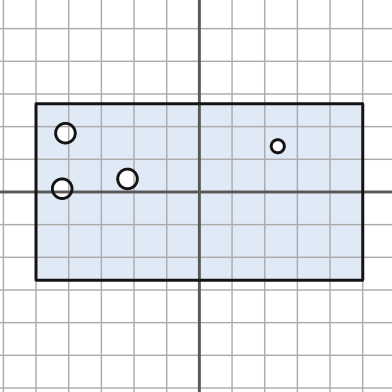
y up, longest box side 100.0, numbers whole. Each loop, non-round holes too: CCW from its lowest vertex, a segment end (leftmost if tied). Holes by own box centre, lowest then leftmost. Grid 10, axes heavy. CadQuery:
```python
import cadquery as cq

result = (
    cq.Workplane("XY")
    .moveTo(-50.0, -27.0)
    .lineTo(50.0, -27.0)
    .lineTo(50.0, 27.0)
    .lineTo(-50.0, 27.0)
    .close()
    .moveTo(-42.0, 1.0)
    .circle(3.0)
    .moveTo(-22.0, 4.0)
    .circle(3.0)
    .moveTo(24.0, 14.0)
    .circle(2.0)
    .moveTo(-41.0, 18.0)
    .circle(3.0)
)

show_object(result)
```